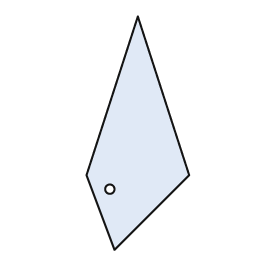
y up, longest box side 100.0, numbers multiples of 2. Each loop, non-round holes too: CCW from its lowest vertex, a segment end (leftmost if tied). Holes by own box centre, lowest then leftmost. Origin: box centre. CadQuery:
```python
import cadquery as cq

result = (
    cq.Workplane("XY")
    .moveTo(-10.0, -50.0)
    .lineTo(22.0, -18.0)
    .lineTo(0.0, 50.0)
    .lineTo(-22.0, -18.0)
    .close()
    .moveTo(-12.0, -24.0)
    .circle(2.0)
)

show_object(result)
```